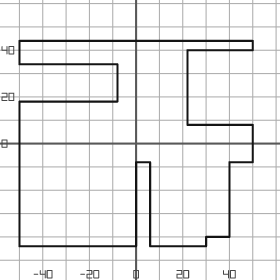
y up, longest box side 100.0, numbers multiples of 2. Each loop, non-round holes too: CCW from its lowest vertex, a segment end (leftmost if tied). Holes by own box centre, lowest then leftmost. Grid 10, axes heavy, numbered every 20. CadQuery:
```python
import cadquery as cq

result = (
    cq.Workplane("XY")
    .moveTo(-50.0, -44.0)
    .lineTo(0.0, -44.0)
    .lineTo(0.0, -8.0)
    .lineTo(6.0, -8.0)
    .lineTo(6.0, -44.0)
    .lineTo(30.0, -44.0)
    .lineTo(30.0, -40.0)
    .lineTo(40.0, -40.0)
    .lineTo(40.0, -8.0)
    .lineTo(50.0, -8.0)
    .lineTo(50.0, 8.0)
    .lineTo(22.0, 8.0)
    .lineTo(22.0, 40.0)
    .lineTo(50.0, 40.0)
    .lineTo(50.0, 44.0)
    .lineTo(-50.0, 44.0)
    .lineTo(-50.0, 34.0)
    .lineTo(-8.0, 34.0)
    .lineTo(-8.0, 18.0)
    .lineTo(-50.0, 18.0)
    .close()
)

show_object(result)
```